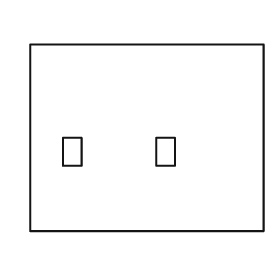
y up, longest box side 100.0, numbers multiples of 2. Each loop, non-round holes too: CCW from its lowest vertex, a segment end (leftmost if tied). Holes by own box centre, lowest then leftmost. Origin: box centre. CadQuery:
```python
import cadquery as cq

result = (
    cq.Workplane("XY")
    .moveTo(-50.0, -40.0)
    .lineTo(50.0, -40.0)
    .lineTo(50.0, 40.0)
    .lineTo(-50.0, 40.0)
    .close()
    .moveTo(-36.0, -12.0)
    .lineTo(-28.0, -12.0)
    .lineTo(-28.0, 0.0)
    .lineTo(-36.0, 0.0)
    .close()
    .moveTo(4.0, -12.0)
    .lineTo(12.0, -12.0)
    .lineTo(12.0, 0.0)
    .lineTo(4.0, 0.0)
    .close()
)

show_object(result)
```